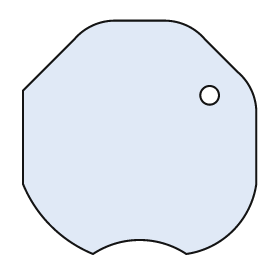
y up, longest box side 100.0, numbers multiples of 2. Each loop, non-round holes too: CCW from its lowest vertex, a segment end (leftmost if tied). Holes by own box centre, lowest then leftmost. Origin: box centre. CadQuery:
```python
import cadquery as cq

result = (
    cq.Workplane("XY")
    .moveTo(-20.0, -50.0)
    .threePointArc((0.0, -44.0), (20.0, -50.0))
    .threePointArc((40.0, -40.0), (50.0, -20.0))
    .lineTo(50.0, 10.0)
    .threePointArc((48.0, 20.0), (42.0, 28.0))
    .lineTo(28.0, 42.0)
    .threePointArc((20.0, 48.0), (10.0, 50.0))
    .lineTo(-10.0, 50.0)
    .threePointArc((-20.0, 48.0), (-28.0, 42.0))
    .lineTo(-50.0, 20.0)
    .lineTo(-50.0, -20.0)
    .threePointArc((-38.0, -38.0), (-20.0, -50.0))
    .close()
    .moveTo(30.0, 18.0)
    .circle(4.0)
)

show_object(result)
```